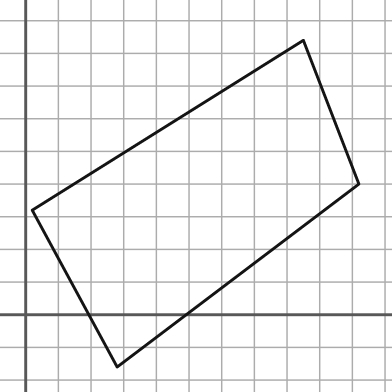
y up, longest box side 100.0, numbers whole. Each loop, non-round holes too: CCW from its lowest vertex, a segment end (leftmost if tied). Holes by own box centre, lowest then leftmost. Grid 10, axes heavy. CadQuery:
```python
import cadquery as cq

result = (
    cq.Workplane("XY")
    .moveTo(28.0, -16.0)
    .lineTo(102.0, 40.0)
    .lineTo(85.0, 84.0)
    .lineTo(2.0, 32.0)
    .close()
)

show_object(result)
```